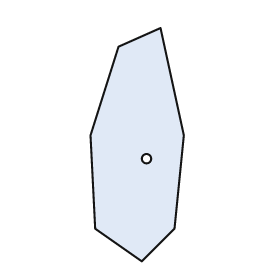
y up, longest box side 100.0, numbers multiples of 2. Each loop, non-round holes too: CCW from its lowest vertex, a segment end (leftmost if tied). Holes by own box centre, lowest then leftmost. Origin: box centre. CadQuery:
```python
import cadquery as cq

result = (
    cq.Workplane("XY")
    .moveTo(2.0, -50.0)
    .lineTo(16.0, -36.0)
    .lineTo(20.0, 4.0)
    .lineTo(10.0, 50.0)
    .lineTo(-8.0, 42.0)
    .lineTo(-20.0, 4.0)
    .lineTo(-18.0, -36.0)
    .close()
    .moveTo(4.0, -6.0)
    .circle(2.0)
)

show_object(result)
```